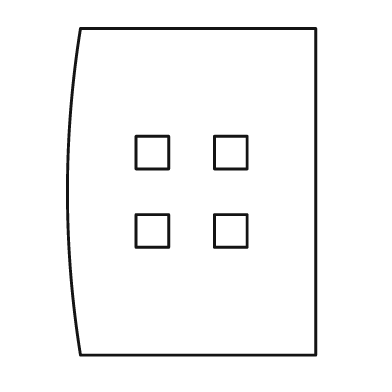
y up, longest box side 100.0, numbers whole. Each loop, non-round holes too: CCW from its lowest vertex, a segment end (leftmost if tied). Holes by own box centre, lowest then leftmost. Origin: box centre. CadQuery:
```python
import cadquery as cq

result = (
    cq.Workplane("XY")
    .moveTo(-34.0, -50.0)
    .lineTo(38.0, -50.0)
    .lineTo(38.0, 50.0)
    .lineTo(-34.0, 50.0)
    .threePointArc((-38.0, 0.0), (-34.0, -50.0))
    .close()
    .moveTo(-17.0, -17.0)
    .lineTo(-7.0, -17.0)
    .lineTo(-7.0, -7.0)
    .lineTo(-17.0, -7.0)
    .close()
    .moveTo(7.0, -17.0)
    .lineTo(17.0, -17.0)
    .lineTo(17.0, -7.0)
    .lineTo(7.0, -7.0)
    .close()
    .moveTo(-17.0, 7.0)
    .lineTo(-7.0, 7.0)
    .lineTo(-7.0, 17.0)
    .lineTo(-17.0, 17.0)
    .close()
    .moveTo(7.0, 7.0)
    .lineTo(17.0, 7.0)
    .lineTo(17.0, 17.0)
    .lineTo(7.0, 17.0)
    .close()
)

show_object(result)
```